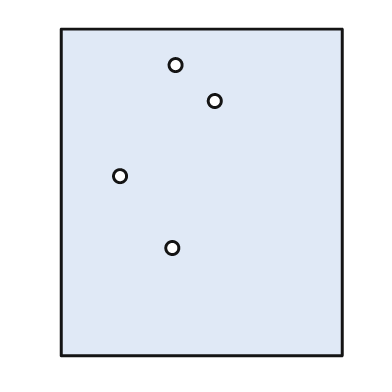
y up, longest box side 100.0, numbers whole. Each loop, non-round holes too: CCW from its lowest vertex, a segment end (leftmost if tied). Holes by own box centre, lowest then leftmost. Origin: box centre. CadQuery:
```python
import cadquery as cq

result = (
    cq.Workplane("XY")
    .moveTo(-43.0, -50.0)
    .lineTo(43.0, -50.0)
    .lineTo(43.0, 50.0)
    .lineTo(-43.0, 50.0)
    .close()
    .moveTo(-9.0, -17.0)
    .circle(2.0)
    .moveTo(-25.0, 5.0)
    .circle(2.0)
    .moveTo(4.0, 28.0)
    .circle(2.0)
    .moveTo(-8.0, 39.0)
    .circle(2.0)
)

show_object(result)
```